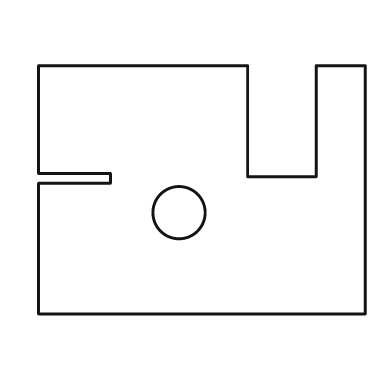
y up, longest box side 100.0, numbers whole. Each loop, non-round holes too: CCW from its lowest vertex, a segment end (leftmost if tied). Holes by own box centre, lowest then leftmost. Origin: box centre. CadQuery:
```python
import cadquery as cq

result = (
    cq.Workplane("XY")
    .moveTo(-50.0, -38.0)
    .lineTo(50.0, -38.0)
    .lineTo(50.0, 38.0)
    .lineTo(35.0, 38.0)
    .lineTo(35.0, 4.0)
    .lineTo(14.0, 4.0)
    .lineTo(14.0, 38.0)
    .lineTo(-50.0, 38.0)
    .lineTo(-50.0, 5.0)
    .lineTo(-28.0, 5.0)
    .lineTo(-28.0, 2.0)
    .lineTo(-50.0, 2.0)
    .close()
    .moveTo(-7.0, -7.0)
    .circle(8.0)
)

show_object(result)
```